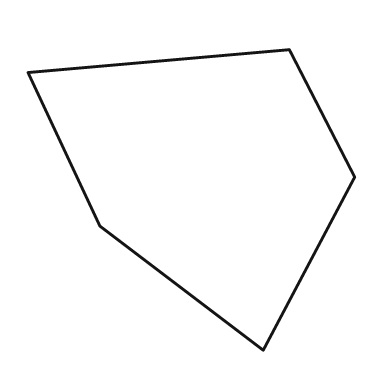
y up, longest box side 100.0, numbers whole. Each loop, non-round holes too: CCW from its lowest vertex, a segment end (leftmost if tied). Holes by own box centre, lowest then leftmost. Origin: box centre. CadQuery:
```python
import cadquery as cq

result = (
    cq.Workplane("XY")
    .moveTo(22.0, -46.0)
    .lineTo(50.0, 7.0)
    .lineTo(30.0, 46.0)
    .lineTo(-50.0, 39.0)
    .lineTo(-28.0, -8.0)
    .close()
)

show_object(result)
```